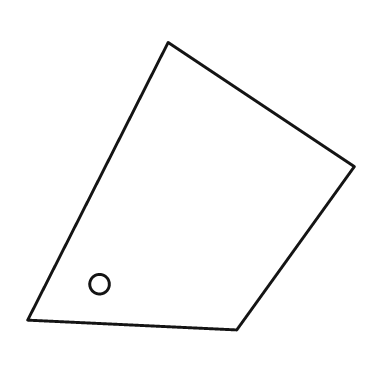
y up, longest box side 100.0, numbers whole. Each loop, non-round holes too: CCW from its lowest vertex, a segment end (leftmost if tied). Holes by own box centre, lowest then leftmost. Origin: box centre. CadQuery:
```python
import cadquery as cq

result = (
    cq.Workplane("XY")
    .moveTo(14.0, -44.0)
    .lineTo(50.0, 6.0)
    .lineTo(-7.0, 44.0)
    .lineTo(-50.0, -41.0)
    .close()
    .moveTo(-28.0, -30.0)
    .circle(3.0)
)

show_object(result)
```